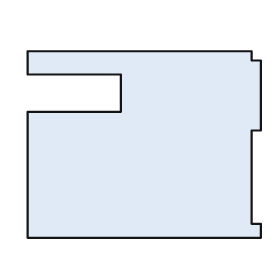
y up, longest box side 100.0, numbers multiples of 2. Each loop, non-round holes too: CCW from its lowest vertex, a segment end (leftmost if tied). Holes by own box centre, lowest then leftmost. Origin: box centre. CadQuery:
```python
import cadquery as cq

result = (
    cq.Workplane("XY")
    .moveTo(-50.0, -40.0)
    .lineTo(50.0, -40.0)
    .lineTo(50.0, -34.0)
    .lineTo(46.0, -34.0)
    .lineTo(46.0, 6.0)
    .lineTo(50.0, 6.0)
    .lineTo(50.0, 36.0)
    .lineTo(46.0, 36.0)
    .lineTo(46.0, 40.0)
    .lineTo(-50.0, 40.0)
    .lineTo(-50.0, 30.0)
    .lineTo(-10.0, 30.0)
    .lineTo(-10.0, 14.0)
    .lineTo(-50.0, 14.0)
    .close()
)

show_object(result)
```